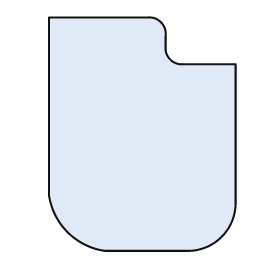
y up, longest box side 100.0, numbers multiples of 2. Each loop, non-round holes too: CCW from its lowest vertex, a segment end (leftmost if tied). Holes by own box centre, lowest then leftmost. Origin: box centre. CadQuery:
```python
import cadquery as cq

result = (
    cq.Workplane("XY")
    .moveTo(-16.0, -50.0)
    .lineTo(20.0, -50.0)
    .threePointArc((34.0, -44.0), (40.0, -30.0))
    .lineTo(40.0, 30.0)
    .lineTo(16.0, 30.0)
    .threePointArc((12.0, 32.0), (10.0, 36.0))
    .lineTo(10.0, 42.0)
    .threePointArc((8.0, 48.0), (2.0, 50.0))
    .lineTo(-40.0, 50.0)
    .lineTo(-40.0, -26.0)
    .threePointArc((-32.0, -42.0), (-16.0, -50.0))
    .close()
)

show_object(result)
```